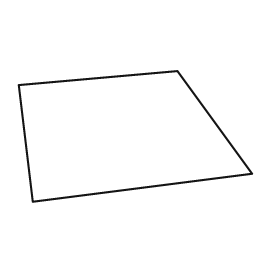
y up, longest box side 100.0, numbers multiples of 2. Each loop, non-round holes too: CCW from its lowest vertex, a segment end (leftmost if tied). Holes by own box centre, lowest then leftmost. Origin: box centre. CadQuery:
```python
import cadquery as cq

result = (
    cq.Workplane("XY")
    .moveTo(-44.0, -28.0)
    .lineTo(50.0, -16.0)
    .lineTo(18.0, 28.0)
    .lineTo(-50.0, 22.0)
    .close()
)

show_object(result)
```